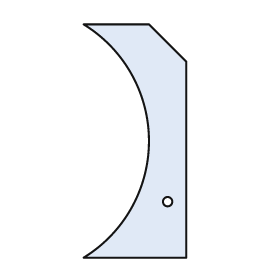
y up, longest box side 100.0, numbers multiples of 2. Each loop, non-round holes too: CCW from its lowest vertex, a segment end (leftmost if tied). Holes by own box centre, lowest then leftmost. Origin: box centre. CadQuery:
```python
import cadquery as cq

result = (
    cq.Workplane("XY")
    .moveTo(-22.0, -50.0)
    .lineTo(22.0, -50.0)
    .lineTo(22.0, 34.0)
    .lineTo(6.0, 50.0)
    .lineTo(-22.0, 50.0)
    .threePointArc((6.0, 0.0), (-22.0, -50.0))
    .close()
    .moveTo(14.0, -26.0)
    .circle(2.0)
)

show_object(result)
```